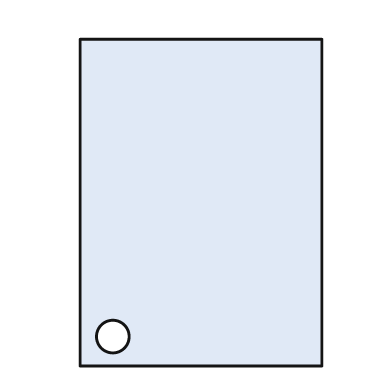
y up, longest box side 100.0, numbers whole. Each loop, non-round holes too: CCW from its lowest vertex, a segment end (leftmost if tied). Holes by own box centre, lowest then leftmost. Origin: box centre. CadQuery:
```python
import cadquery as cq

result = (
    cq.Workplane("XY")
    .moveTo(-37.0, -50.0)
    .lineTo(37.0, -50.0)
    .lineTo(37.0, 50.0)
    .lineTo(-37.0, 50.0)
    .close()
    .moveTo(-27.0, -41.0)
    .circle(5.0)
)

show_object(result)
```